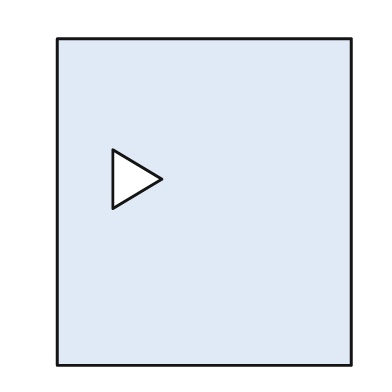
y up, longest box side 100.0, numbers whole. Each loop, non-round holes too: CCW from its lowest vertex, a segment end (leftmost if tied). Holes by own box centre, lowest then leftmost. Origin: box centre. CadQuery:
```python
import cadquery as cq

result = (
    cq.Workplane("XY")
    .moveTo(-45.0, -50.0)
    .lineTo(45.0, -50.0)
    .lineTo(45.0, 50.0)
    .lineTo(-45.0, 50.0)
    .close()
    .moveTo(-28.0, -2.0)
    .lineTo(-13.0, 7.0)
    .lineTo(-28.0, 16.0)
    .close()
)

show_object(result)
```